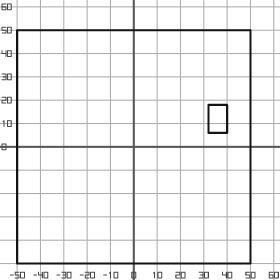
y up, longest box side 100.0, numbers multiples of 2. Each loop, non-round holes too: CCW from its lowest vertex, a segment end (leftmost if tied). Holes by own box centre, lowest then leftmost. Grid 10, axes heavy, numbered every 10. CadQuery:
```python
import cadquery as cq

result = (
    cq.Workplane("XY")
    .moveTo(-50.0, -50.0)
    .lineTo(50.0, -50.0)
    .lineTo(50.0, 50.0)
    .lineTo(-50.0, 50.0)
    .close()
    .moveTo(32.0, 6.0)
    .lineTo(40.0, 6.0)
    .lineTo(40.0, 18.0)
    .lineTo(32.0, 18.0)
    .close()
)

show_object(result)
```